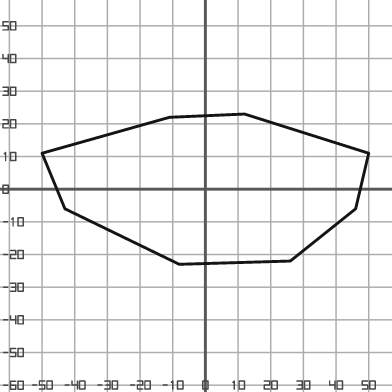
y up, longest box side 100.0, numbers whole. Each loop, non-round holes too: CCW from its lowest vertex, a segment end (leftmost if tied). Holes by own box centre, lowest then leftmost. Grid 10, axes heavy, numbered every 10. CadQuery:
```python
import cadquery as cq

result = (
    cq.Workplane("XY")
    .moveTo(-8.0, -23.0)
    .lineTo(26.0, -22.0)
    .lineTo(46.0, -6.0)
    .lineTo(50.0, 11.0)
    .lineTo(12.0, 23.0)
    .lineTo(-11.0, 22.0)
    .lineTo(-50.0, 11.0)
    .lineTo(-43.0, -6.0)
    .close()
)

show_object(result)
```